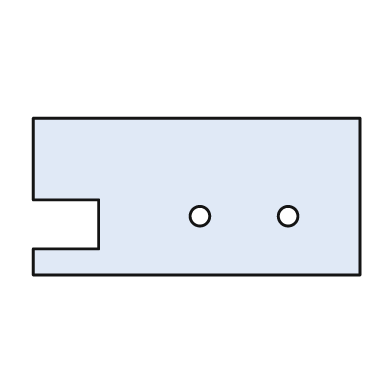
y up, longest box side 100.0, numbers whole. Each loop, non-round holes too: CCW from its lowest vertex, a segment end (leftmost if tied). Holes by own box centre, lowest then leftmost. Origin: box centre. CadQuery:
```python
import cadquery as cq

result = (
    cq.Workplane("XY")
    .moveTo(-50.0, -24.0)
    .lineTo(50.0, -24.0)
    .lineTo(50.0, 24.0)
    .lineTo(-50.0, 24.0)
    .lineTo(-50.0, -1.0)
    .lineTo(-30.0, -1.0)
    .lineTo(-30.0, -16.0)
    .lineTo(-50.0, -16.0)
    .close()
    .moveTo(1.0, -6.0)
    .circle(3.0)
    .moveTo(28.0, -6.0)
    .circle(3.0)
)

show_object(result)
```